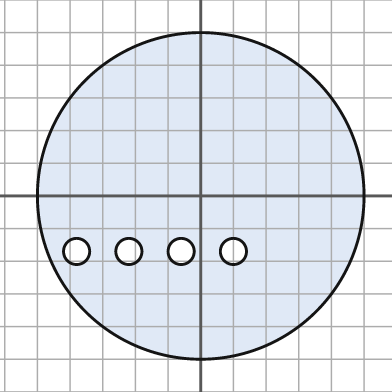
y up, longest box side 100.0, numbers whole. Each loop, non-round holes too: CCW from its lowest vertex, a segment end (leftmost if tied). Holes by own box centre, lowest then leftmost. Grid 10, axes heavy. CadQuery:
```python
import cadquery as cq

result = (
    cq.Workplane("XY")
    .moveTo(0.0, 0.0)
    .circle(50.0)
    .moveTo(-38.0, -17.0)
    .circle(4.0)
    .moveTo(-22.0, -17.0)
    .circle(4.0)
    .moveTo(-6.0, -17.0)
    .circle(4.0)
    .moveTo(10.0, -17.0)
    .circle(4.0)
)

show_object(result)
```